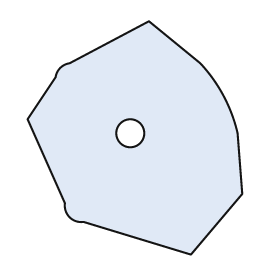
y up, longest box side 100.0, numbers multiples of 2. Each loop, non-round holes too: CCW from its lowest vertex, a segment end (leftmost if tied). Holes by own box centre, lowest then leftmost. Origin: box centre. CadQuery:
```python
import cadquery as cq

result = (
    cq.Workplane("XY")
    .moveTo(24.0, -50.0)
    .lineTo(46.0, -24.0)
    .lineTo(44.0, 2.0)
    .threePointArc((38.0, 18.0), (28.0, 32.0))
    .lineTo(6.0, 50.0)
    .lineTo(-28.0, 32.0)
    .threePointArc((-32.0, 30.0), (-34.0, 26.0))
    .lineTo(-46.0, 8.0)
    .lineTo(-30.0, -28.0)
    .threePointArc((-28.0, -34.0), (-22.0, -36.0))
    .close()
    .moveTo(-2.0, 2.0)
    .circle(6.0)
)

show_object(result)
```